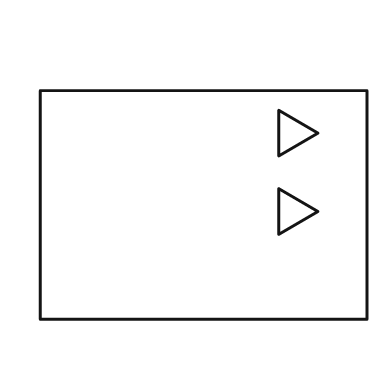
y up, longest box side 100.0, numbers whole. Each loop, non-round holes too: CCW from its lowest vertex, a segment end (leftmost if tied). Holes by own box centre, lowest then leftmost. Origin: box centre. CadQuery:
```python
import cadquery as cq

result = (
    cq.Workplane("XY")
    .moveTo(-50.0, -35.0)
    .lineTo(50.0, -35.0)
    .lineTo(50.0, 35.0)
    .lineTo(-50.0, 35.0)
    .close()
    .moveTo(23.0, -9.0)
    .lineTo(35.0, -2.0)
    .lineTo(23.0, 5.0)
    .close()
    .moveTo(23.0, 15.0)
    .lineTo(35.0, 22.0)
    .lineTo(23.0, 29.0)
    .close()
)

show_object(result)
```